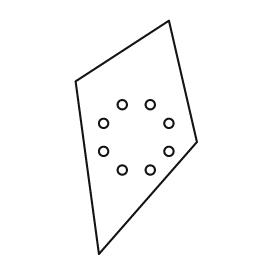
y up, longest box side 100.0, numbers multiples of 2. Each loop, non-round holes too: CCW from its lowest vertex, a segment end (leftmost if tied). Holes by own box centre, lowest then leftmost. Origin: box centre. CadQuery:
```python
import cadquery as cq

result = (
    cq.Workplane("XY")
    .moveTo(-16.0, -50.0)
    .lineTo(26.0, -2.0)
    .lineTo(14.0, 50.0)
    .lineTo(-26.0, 24.0)
    .close()
    .moveTo(-6.0, -14.0)
    .circle(2.0)
    .moveTo(6.0, -14.0)
    .circle(2.0)
    .moveTo(-14.0, -6.0)
    .circle(2.0)
    .moveTo(14.0, -6.0)
    .circle(2.0)
    .moveTo(-14.0, 6.0)
    .circle(2.0)
    .moveTo(14.0, 6.0)
    .circle(2.0)
    .moveTo(-6.0, 14.0)
    .circle(2.0)
    .moveTo(6.0, 14.0)
    .circle(2.0)
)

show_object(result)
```